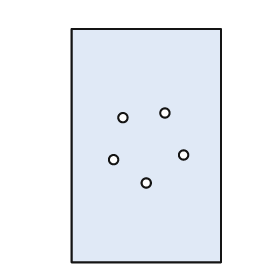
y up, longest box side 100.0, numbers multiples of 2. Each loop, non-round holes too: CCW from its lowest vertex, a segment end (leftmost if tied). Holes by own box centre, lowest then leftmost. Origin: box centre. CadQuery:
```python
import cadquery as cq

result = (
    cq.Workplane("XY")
    .moveTo(-32.0, -50.0)
    .lineTo(32.0, -50.0)
    .lineTo(32.0, 50.0)
    .lineTo(-32.0, 50.0)
    .close()
    .moveTo(0.0, -16.0)
    .circle(2.0)
    .moveTo(-14.0, -6.0)
    .circle(2.0)
    .moveTo(16.0, -4.0)
    .circle(2.0)
    .moveTo(-10.0, 12.0)
    .circle(2.0)
    .moveTo(8.0, 14.0)
    .circle(2.0)
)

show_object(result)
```